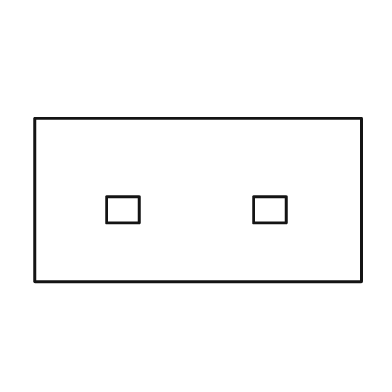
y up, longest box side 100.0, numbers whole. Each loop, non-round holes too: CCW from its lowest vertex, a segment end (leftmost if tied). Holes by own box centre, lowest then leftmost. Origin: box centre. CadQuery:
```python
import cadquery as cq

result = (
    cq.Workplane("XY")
    .moveTo(-50.0, -25.0)
    .lineTo(50.0, -25.0)
    .lineTo(50.0, 25.0)
    .lineTo(-50.0, 25.0)
    .close()
    .moveTo(-28.0, -7.0)
    .lineTo(-18.0, -7.0)
    .lineTo(-18.0, 1.0)
    .lineTo(-28.0, 1.0)
    .close()
    .moveTo(17.0, -7.0)
    .lineTo(27.0, -7.0)
    .lineTo(27.0, 1.0)
    .lineTo(17.0, 1.0)
    .close()
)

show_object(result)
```